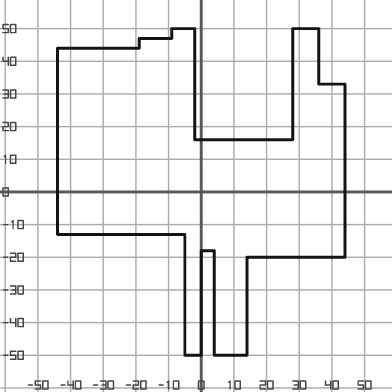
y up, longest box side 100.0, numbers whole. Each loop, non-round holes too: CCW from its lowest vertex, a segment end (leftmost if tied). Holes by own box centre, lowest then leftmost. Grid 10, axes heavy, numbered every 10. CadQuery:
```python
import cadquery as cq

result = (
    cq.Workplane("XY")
    .moveTo(-5.0, -50.0)
    .lineTo(0.0, -50.0)
    .lineTo(0.0, -18.0)
    .lineTo(4.0, -18.0)
    .lineTo(4.0, -50.0)
    .lineTo(14.0, -50.0)
    .lineTo(14.0, -20.0)
    .lineTo(44.0, -20.0)
    .lineTo(44.0, 33.0)
    .lineTo(36.0, 33.0)
    .lineTo(36.0, 50.0)
    .lineTo(28.0, 50.0)
    .lineTo(28.0, 16.0)
    .lineTo(-2.0, 16.0)
    .lineTo(-2.0, 50.0)
    .lineTo(-9.0, 50.0)
    .lineTo(-9.0, 47.0)
    .lineTo(-19.0, 47.0)
    .lineTo(-19.0, 44.0)
    .lineTo(-44.0, 44.0)
    .lineTo(-44.0, -13.0)
    .lineTo(-5.0, -13.0)
    .close()
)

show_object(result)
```